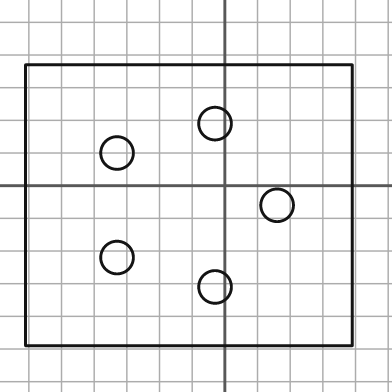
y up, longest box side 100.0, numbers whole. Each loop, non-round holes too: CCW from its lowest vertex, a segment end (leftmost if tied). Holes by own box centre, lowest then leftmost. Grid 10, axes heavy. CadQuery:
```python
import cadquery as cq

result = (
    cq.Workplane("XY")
    .moveTo(-61.0, -49.0)
    .lineTo(39.0, -49.0)
    .lineTo(39.0, 37.0)
    .lineTo(-61.0, 37.0)
    .close()
    .moveTo(-3.0, -31.0)
    .circle(5.0)
    .moveTo(-33.0, -22.0)
    .circle(5.0)
    .moveTo(16.0, -6.0)
    .circle(5.0)
    .moveTo(-33.0, 10.0)
    .circle(5.0)
    .moveTo(-3.0, 19.0)
    .circle(5.0)
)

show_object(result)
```